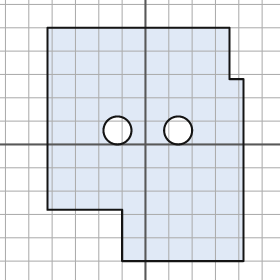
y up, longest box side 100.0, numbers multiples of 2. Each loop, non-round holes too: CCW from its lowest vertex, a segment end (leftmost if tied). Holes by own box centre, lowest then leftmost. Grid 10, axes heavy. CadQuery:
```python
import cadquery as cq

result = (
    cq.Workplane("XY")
    .moveTo(-10.0, -50.0)
    .lineTo(42.0, -50.0)
    .lineTo(42.0, 28.0)
    .lineTo(36.0, 28.0)
    .lineTo(36.0, 50.0)
    .lineTo(-42.0, 50.0)
    .lineTo(-42.0, -28.0)
    .lineTo(-10.0, -28.0)
    .close()
    .moveTo(-12.0, 6.0)
    .circle(6.0)
    .moveTo(14.0, 6.0)
    .circle(6.0)
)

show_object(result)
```